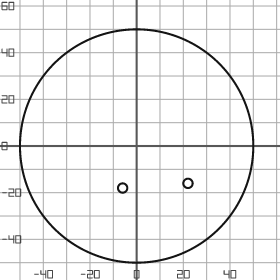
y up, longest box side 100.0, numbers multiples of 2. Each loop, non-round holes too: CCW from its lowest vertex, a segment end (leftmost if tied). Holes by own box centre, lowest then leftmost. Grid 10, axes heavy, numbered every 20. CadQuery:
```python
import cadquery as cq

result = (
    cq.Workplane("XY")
    .moveTo(0.0, 0.0)
    .circle(50.0)
    .moveTo(-6.0, -18.0)
    .circle(2.0)
    .moveTo(22.0, -16.0)
    .circle(2.0)
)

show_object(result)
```